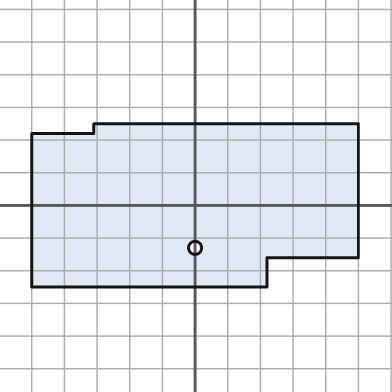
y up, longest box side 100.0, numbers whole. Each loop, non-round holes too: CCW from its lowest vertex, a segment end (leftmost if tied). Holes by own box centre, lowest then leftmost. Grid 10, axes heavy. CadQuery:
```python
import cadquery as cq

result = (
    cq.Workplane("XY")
    .moveTo(-50.0, -25.0)
    .lineTo(22.0, -25.0)
    .lineTo(22.0, -16.0)
    .lineTo(50.0, -16.0)
    .lineTo(50.0, 25.0)
    .lineTo(-31.0, 25.0)
    .lineTo(-31.0, 22.0)
    .lineTo(-50.0, 22.0)
    .close()
    .moveTo(0.0, -13.0)
    .circle(2.0)
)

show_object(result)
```